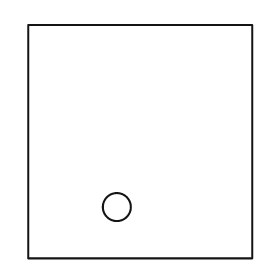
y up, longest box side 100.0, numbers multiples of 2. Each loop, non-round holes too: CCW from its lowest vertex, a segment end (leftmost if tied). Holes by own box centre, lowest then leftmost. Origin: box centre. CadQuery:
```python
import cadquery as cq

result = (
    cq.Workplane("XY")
    .moveTo(-48.0, -50.0)
    .lineTo(48.0, -50.0)
    .lineTo(48.0, 50.0)
    .lineTo(-48.0, 50.0)
    .close()
    .moveTo(-10.0, -28.0)
    .circle(6.0)
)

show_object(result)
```